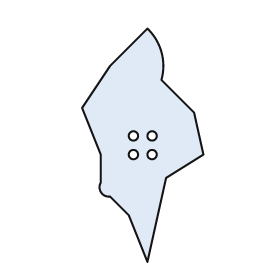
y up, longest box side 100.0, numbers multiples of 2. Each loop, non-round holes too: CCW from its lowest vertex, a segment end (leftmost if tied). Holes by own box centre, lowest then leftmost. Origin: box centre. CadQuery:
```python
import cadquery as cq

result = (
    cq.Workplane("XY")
    .moveTo(2.0, -50.0)
    .lineTo(10.0, -14.0)
    .lineTo(26.0, -4.0)
    .lineTo(22.0, 14.0)
    .lineTo(8.0, 28.0)
    .threePointArc((8.0, 40.0), (2.0, 50.0))
    .lineTo(-14.0, 34.0)
    .lineTo(-26.0, 16.0)
    .lineTo(-18.0, -4.0)
    .lineTo(-18.0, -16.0)
    .threePointArc((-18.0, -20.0), (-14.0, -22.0))
    .lineTo(-6.0, -30.0)
    .close()
    .moveTo(-4.0, -4.0)
    .circle(2.0)
    .moveTo(4.0, -4.0)
    .circle(2.0)
    .moveTo(-4.0, 4.0)
    .circle(2.0)
    .moveTo(4.0, 4.0)
    .circle(2.0)
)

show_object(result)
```